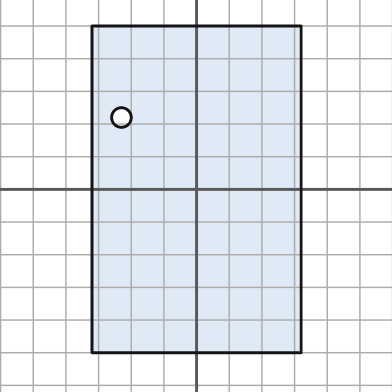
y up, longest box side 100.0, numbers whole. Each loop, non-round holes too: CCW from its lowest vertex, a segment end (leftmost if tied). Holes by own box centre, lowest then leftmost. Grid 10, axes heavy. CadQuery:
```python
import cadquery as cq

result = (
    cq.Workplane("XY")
    .moveTo(-32.0, -50.0)
    .lineTo(32.0, -50.0)
    .lineTo(32.0, 50.0)
    .lineTo(-32.0, 50.0)
    .close()
    .moveTo(-23.0, 22.0)
    .circle(3.0)
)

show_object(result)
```